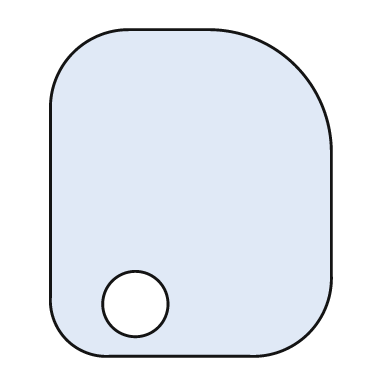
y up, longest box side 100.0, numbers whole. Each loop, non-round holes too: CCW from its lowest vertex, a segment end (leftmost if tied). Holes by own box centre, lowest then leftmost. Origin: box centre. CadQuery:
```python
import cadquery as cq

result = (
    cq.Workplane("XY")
    .moveTo(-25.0, -50.0)
    .lineTo(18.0, -50.0)
    .threePointArc((36.0, -43.0), (43.0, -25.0))
    .lineTo(43.0, 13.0)
    .threePointArc((32.0, 39.0), (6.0, 50.0))
    .lineTo(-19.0, 50.0)
    .threePointArc((-36.0, 43.0), (-43.0, 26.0))
    .lineTo(-43.0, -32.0)
    .threePointArc((-38.0, -45.0), (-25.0, -50.0))
    .close()
    .moveTo(-17.0, -34.0)
    .circle(10.0)
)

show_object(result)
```